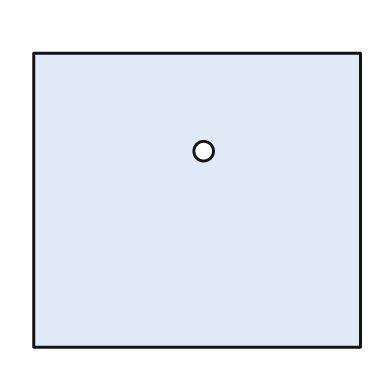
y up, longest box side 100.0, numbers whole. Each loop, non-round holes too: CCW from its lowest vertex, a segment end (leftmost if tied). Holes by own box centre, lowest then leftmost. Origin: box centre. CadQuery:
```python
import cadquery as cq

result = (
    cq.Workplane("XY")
    .moveTo(-50.0, -45.0)
    .lineTo(50.0, -45.0)
    .lineTo(50.0, 45.0)
    .lineTo(-50.0, 45.0)
    .close()
    .moveTo(2.0, 15.0)
    .circle(3.0)
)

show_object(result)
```